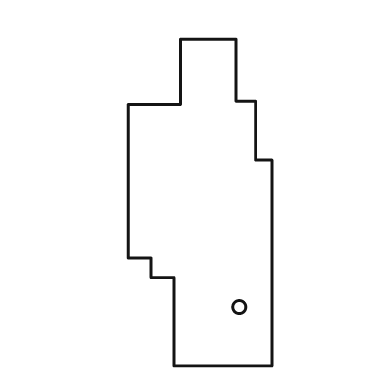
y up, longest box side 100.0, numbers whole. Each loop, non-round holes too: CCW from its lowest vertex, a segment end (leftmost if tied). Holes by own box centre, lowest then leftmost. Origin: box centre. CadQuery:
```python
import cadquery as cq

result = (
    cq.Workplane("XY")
    .moveTo(-8.0, -50.0)
    .lineTo(22.0, -50.0)
    .lineTo(22.0, 13.0)
    .lineTo(17.0, 13.0)
    .lineTo(17.0, 31.0)
    .lineTo(11.0, 31.0)
    .lineTo(11.0, 50.0)
    .lineTo(-6.0, 50.0)
    .lineTo(-6.0, 30.0)
    .lineTo(-22.0, 30.0)
    .lineTo(-22.0, -17.0)
    .lineTo(-15.0, -17.0)
    .lineTo(-15.0, -23.0)
    .lineTo(-8.0, -23.0)
    .close()
    .moveTo(12.0, -32.0)
    .circle(2.0)
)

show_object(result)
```